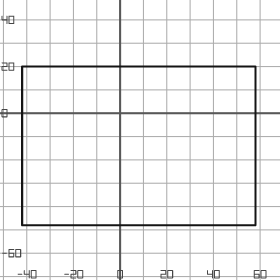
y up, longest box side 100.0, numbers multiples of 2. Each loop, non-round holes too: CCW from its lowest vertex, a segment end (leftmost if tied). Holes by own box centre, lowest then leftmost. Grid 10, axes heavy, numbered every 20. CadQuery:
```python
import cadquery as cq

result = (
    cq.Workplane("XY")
    .moveTo(-42.0, -48.0)
    .lineTo(58.0, -48.0)
    .lineTo(58.0, 20.0)
    .lineTo(-42.0, 20.0)
    .close()
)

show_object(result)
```